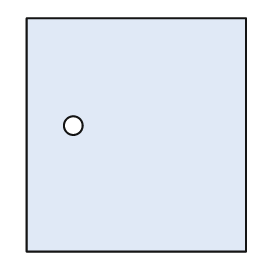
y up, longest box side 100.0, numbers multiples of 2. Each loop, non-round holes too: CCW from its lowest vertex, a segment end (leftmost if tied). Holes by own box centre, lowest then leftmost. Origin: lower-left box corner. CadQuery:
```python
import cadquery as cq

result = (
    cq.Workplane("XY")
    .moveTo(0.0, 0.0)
    .lineTo(94.0, 0.0)
    .lineTo(94.0, 100.0)
    .lineTo(0.0, 100.0)
    .close()
    .moveTo(20.0, 54.0)
    .circle(4.0)
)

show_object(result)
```